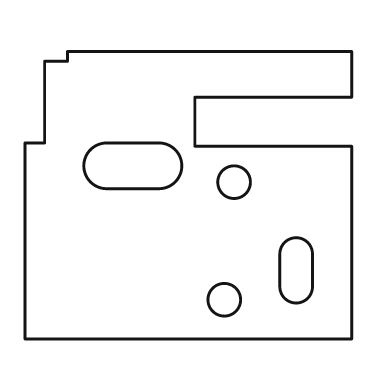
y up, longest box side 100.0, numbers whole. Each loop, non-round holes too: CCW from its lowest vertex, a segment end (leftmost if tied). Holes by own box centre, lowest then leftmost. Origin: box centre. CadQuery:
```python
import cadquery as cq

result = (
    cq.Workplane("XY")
    .moveTo(-50.0, -44.0)
    .lineTo(50.0, -44.0)
    .lineTo(50.0, 15.0)
    .lineTo(2.0, 15.0)
    .lineTo(2.0, 30.0)
    .lineTo(50.0, 30.0)
    .lineTo(50.0, 44.0)
    .lineTo(-37.0, 44.0)
    .lineTo(-37.0, 41.0)
    .lineTo(-44.0, 41.0)
    .lineTo(-44.0, 16.0)
    .lineTo(-50.0, 16.0)
    .close()
    .moveTo(11.0, -32.0)
    .circle(5.0)
    .moveTo(28.0, -28.0)
    .threePointArc((33.0, -33.0), (38.0, -28.0))
    .lineTo(38.0, -18.0)
    .threePointArc((33.0, -13.0), (28.0, -18.0))
    .close()
    .moveTo(14.0, 4.0)
    .circle(5.0)
    .moveTo(-25.0, 2.0)
    .lineTo(-9.0, 2.0)
    .threePointArc((-2.0, 9.0), (-9.0, 16.0))
    .lineTo(-25.0, 16.0)
    .threePointArc((-32.0, 9.0), (-25.0, 2.0))
    .close()
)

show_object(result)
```